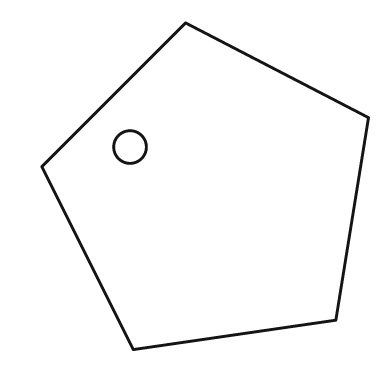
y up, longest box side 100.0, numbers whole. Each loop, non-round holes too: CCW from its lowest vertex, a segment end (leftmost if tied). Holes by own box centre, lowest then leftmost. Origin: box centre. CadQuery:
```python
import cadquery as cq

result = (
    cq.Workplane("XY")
    .moveTo(-22.0, -50.0)
    .lineTo(40.0, -41.0)
    .lineTo(50.0, 21.0)
    .lineTo(-6.0, 50.0)
    .lineTo(-50.0, 6.0)
    .close()
    .moveTo(-23.0, 12.0)
    .circle(5.0)
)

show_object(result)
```